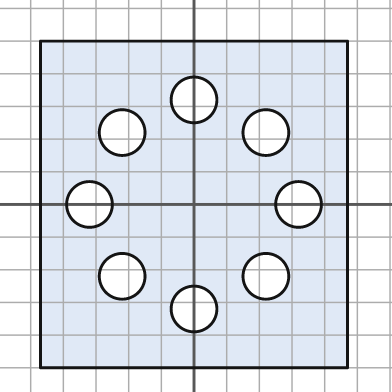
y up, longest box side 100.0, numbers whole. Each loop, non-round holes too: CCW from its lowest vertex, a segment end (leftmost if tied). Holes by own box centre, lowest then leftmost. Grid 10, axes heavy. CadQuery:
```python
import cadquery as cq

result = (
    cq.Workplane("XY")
    .moveTo(-47.0, -50.0)
    .lineTo(47.0, -50.0)
    .lineTo(47.0, 50.0)
    .lineTo(-47.0, 50.0)
    .close()
    .moveTo(0.0, -32.0)
    .circle(7.0)
    .moveTo(-22.0, -22.0)
    .circle(7.0)
    .moveTo(22.0, -22.0)
    .circle(7.0)
    .moveTo(-32.0, 0.0)
    .circle(7.0)
    .moveTo(32.0, 0.0)
    .circle(7.0)
    .moveTo(-22.0, 22.0)
    .circle(7.0)
    .moveTo(22.0, 22.0)
    .circle(7.0)
    .moveTo(0.0, 32.0)
    .circle(7.0)
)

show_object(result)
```